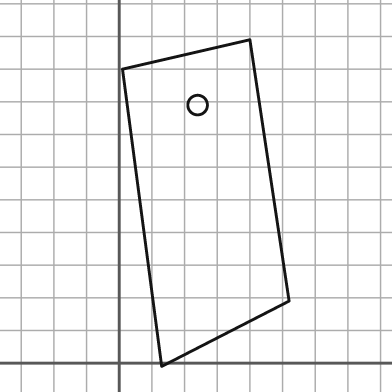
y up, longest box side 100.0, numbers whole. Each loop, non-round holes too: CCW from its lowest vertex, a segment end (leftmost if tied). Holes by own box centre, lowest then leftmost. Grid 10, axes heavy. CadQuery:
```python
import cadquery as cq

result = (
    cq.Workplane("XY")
    .moveTo(13.0, -1.0)
    .lineTo(52.0, 19.0)
    .lineTo(40.0, 99.0)
    .lineTo(1.0, 90.0)
    .close()
    .moveTo(24.0, 79.0)
    .circle(3.0)
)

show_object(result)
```